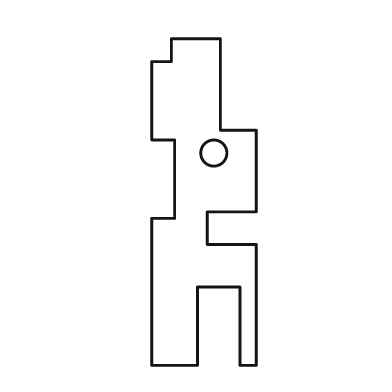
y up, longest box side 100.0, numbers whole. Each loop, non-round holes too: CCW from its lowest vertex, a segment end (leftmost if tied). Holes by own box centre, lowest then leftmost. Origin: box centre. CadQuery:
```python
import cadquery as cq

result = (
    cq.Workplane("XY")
    .moveTo(-16.0, -50.0)
    .lineTo(-2.0, -50.0)
    .lineTo(-2.0, -26.0)
    .lineTo(11.0, -26.0)
    .lineTo(11.0, -50.0)
    .lineTo(16.0, -50.0)
    .lineTo(16.0, -13.0)
    .lineTo(1.0, -13.0)
    .lineTo(1.0, -3.0)
    .lineTo(16.0, -3.0)
    .lineTo(16.0, 22.0)
    .lineTo(5.0, 22.0)
    .lineTo(5.0, 50.0)
    .lineTo(-10.0, 50.0)
    .lineTo(-10.0, 43.0)
    .lineTo(-16.0, 43.0)
    .lineTo(-16.0, 19.0)
    .lineTo(-9.0, 19.0)
    .lineTo(-9.0, -5.0)
    .lineTo(-16.0, -5.0)
    .close()
    .moveTo(3.0, 15.0)
    .circle(4.0)
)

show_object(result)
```